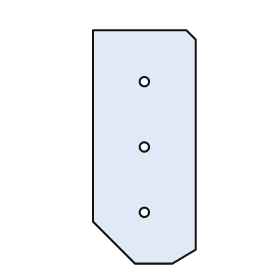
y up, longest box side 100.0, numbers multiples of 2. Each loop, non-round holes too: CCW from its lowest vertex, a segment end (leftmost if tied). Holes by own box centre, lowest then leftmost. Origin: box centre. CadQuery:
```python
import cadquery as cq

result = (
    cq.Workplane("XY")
    .moveTo(-4.0, -50.0)
    .lineTo(12.0, -50.0)
    .lineTo(22.0, -44.0)
    .lineTo(22.0, 46.0)
    .lineTo(18.0, 50.0)
    .lineTo(-22.0, 50.0)
    .lineTo(-22.0, -32.0)
    .close()
    .moveTo(0.0, -28.0)
    .circle(2.0)
    .moveTo(0.0, 0.0)
    .circle(2.0)
    .moveTo(0.0, 28.0)
    .circle(2.0)
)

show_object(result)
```